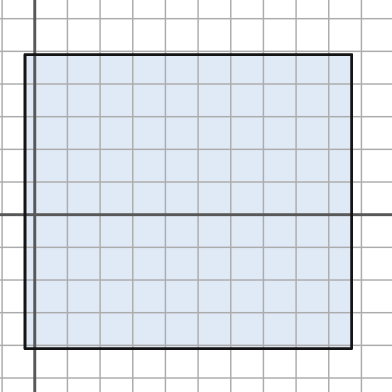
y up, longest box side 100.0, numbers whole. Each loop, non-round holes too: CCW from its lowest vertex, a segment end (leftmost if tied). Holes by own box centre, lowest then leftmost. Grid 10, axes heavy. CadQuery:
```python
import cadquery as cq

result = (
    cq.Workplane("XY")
    .moveTo(-3.0, -41.0)
    .lineTo(97.0, -41.0)
    .lineTo(97.0, 49.0)
    .lineTo(-3.0, 49.0)
    .close()
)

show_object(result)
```